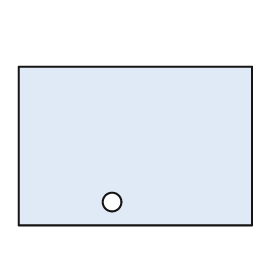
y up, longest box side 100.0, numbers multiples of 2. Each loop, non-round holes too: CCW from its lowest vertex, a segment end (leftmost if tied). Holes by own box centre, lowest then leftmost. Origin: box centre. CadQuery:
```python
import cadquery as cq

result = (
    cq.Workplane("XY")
    .moveTo(-50.0, -34.0)
    .lineTo(50.0, -34.0)
    .lineTo(50.0, 34.0)
    .lineTo(-50.0, 34.0)
    .close()
    .moveTo(-10.0, -24.0)
    .circle(4.0)
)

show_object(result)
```